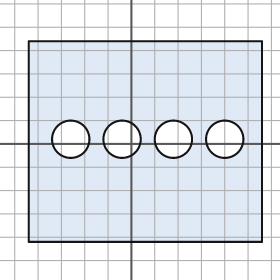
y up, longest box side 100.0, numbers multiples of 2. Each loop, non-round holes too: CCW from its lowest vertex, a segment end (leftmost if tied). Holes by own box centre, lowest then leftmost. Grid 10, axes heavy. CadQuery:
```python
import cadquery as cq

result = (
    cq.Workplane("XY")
    .moveTo(-44.0, -42.0)
    .lineTo(56.0, -42.0)
    .lineTo(56.0, 44.0)
    .lineTo(-44.0, 44.0)
    .close()
    .moveTo(-26.0, 2.0)
    .circle(8.0)
    .moveTo(-4.0, 2.0)
    .circle(8.0)
    .moveTo(18.0, 2.0)
    .circle(8.0)
    .moveTo(40.0, 2.0)
    .circle(8.0)
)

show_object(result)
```